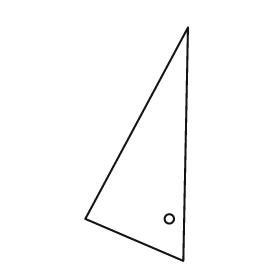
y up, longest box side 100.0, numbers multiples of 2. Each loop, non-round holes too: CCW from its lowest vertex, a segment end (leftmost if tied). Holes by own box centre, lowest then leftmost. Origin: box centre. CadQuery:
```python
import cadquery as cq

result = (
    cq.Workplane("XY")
    .moveTo(20.0, -50.0)
    .lineTo(22.0, 50.0)
    .lineTo(-22.0, -32.0)
    .close()
    .moveTo(14.0, -32.0)
    .circle(2.0)
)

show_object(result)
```